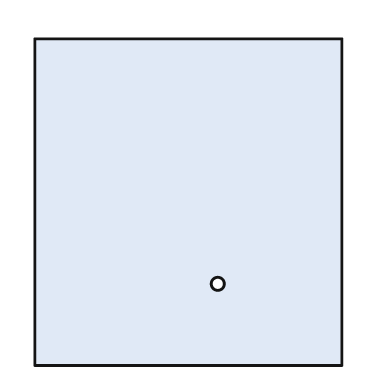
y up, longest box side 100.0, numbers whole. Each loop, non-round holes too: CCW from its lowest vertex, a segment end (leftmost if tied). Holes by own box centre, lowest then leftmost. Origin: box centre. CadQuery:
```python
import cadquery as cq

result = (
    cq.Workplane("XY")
    .moveTo(-47.0, -50.0)
    .lineTo(47.0, -50.0)
    .lineTo(47.0, 50.0)
    .lineTo(-47.0, 50.0)
    .close()
    .moveTo(9.0, -25.0)
    .circle(2.0)
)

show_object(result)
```